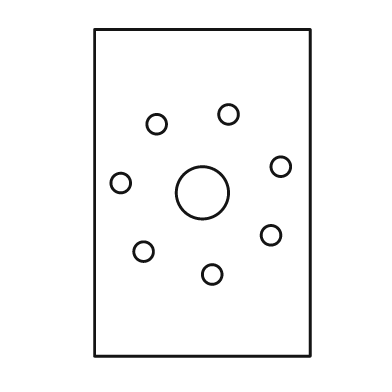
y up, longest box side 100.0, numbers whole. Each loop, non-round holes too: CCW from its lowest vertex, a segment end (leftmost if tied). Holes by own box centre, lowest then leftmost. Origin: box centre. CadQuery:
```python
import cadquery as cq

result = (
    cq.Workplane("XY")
    .moveTo(-33.0, -50.0)
    .lineTo(33.0, -50.0)
    .lineTo(33.0, 50.0)
    .lineTo(-33.0, 50.0)
    .close()
    .moveTo(3.0, -25.0)
    .circle(3.0)
    .moveTo(-18.0, -18.0)
    .circle(3.0)
    .moveTo(21.0, -13.0)
    .circle(3.0)
    .moveTo(0.0, 0.0)
    .circle(8.0)
    .moveTo(-25.0, 3.0)
    .circle(3.0)
    .moveTo(24.0, 8.0)
    .circle(3.0)
    .moveTo(-14.0, 21.0)
    .circle(3.0)
    .moveTo(8.0, 24.0)
    .circle(3.0)
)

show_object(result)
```